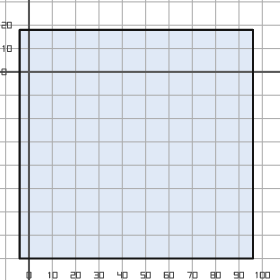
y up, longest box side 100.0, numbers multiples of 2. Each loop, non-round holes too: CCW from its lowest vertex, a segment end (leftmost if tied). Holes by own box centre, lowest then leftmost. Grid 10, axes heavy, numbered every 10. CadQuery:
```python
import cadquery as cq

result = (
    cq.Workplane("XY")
    .moveTo(-4.0, -80.0)
    .lineTo(96.0, -80.0)
    .lineTo(96.0, 18.0)
    .lineTo(-4.0, 18.0)
    .close()
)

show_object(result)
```